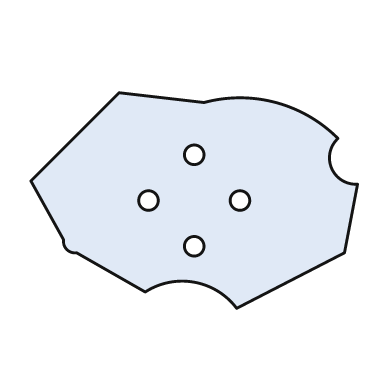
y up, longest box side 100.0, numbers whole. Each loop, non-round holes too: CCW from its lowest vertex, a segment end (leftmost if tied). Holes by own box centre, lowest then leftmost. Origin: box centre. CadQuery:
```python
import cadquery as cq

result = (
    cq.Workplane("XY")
    .moveTo(13.0, -33.0)
    .lineTo(46.0, -16.0)
    .lineTo(50.0, 5.0)
    .threePointArc((42.0, 10.0), (44.0, 19.0))
    .threePointArc((25.0, 30.0), (3.0, 30.0))
    .lineTo(-23.0, 33.0)
    .lineTo(-50.0, 6.0)
    .lineTo(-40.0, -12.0)
    .threePointArc((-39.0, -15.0), (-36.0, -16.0))
    .lineTo(-15.0, -28.0)
    .threePointArc((0.0, -25.0), (13.0, -33.0))
    .close()
    .moveTo(0.0, -14.0)
    .circle(3.0)
    .moveTo(-14.0, 0.0)
    .circle(3.0)
    .moveTo(14.0, 0.0)
    .circle(3.0)
    .moveTo(0.0, 14.0)
    .circle(3.0)
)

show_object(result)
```